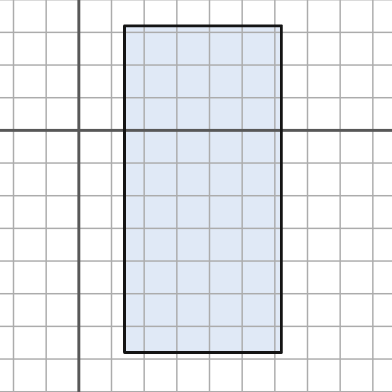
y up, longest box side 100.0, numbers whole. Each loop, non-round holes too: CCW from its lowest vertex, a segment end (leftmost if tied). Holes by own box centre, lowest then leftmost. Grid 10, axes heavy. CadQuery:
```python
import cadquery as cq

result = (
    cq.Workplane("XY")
    .moveTo(14.0, -68.0)
    .lineTo(62.0, -68.0)
    .lineTo(62.0, 32.0)
    .lineTo(14.0, 32.0)
    .close()
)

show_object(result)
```